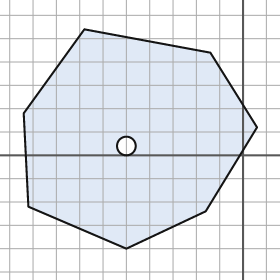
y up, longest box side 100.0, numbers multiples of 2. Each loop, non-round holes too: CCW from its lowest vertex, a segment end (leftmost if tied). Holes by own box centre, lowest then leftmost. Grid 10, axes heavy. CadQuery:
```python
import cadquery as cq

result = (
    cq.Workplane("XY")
    .moveTo(-50.0, -40.0)
    .lineTo(-16.0, -24.0)
    .lineTo(6.0, 12.0)
    .lineTo(-14.0, 44.0)
    .lineTo(-68.0, 54.0)
    .lineTo(-94.0, 18.0)
    .lineTo(-92.0, -22.0)
    .close()
    .moveTo(-50.0, 4.0)
    .circle(4.0)
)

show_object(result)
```